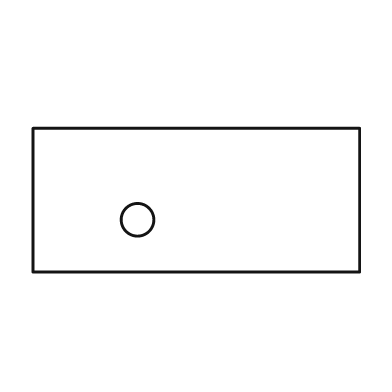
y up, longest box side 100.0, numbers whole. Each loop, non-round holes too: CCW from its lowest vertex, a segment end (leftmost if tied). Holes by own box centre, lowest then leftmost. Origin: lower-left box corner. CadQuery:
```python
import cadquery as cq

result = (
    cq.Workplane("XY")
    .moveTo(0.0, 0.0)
    .lineTo(100.0, 0.0)
    .lineTo(100.0, 44.0)
    .lineTo(0.0, 44.0)
    .close()
    .moveTo(32.0, 16.0)
    .circle(5.0)
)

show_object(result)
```